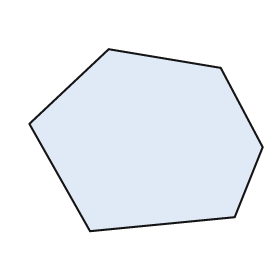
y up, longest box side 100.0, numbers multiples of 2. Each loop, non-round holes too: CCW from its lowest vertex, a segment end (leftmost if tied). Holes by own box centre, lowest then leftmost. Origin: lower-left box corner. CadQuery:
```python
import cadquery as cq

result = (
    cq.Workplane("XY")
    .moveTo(26.0, 0.0)
    .lineTo(88.0, 6.0)
    .lineTo(100.0, 36.0)
    .lineTo(82.0, 70.0)
    .lineTo(34.0, 78.0)
    .lineTo(0.0, 46.0)
    .close()
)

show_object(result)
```